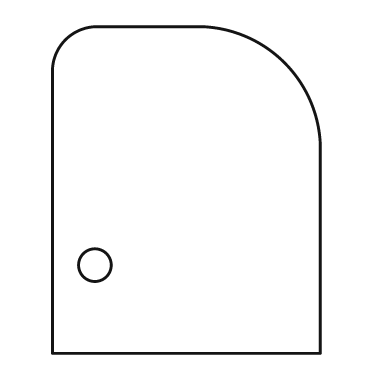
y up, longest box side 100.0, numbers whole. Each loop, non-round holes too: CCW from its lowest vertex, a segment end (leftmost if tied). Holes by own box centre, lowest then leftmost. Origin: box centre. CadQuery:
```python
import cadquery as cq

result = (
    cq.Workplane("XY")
    .moveTo(-41.0, -50.0)
    .lineTo(41.0, -50.0)
    .lineTo(41.0, 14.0)
    .threePointArc((30.0, 39.0), (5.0, 50.0))
    .lineTo(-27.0, 50.0)
    .threePointArc((-37.0, 46.0), (-41.0, 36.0))
    .close()
    .moveTo(-28.0, -23.0)
    .circle(5.0)
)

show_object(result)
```